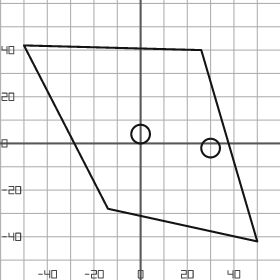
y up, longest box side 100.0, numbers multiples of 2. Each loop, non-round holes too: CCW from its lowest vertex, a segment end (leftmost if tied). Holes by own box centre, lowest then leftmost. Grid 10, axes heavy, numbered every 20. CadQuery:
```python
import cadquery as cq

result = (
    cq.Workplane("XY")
    .moveTo(50.0, -42.0)
    .lineTo(26.0, 40.0)
    .lineTo(-50.0, 42.0)
    .lineTo(-14.0, -28.0)
    .close()
    .moveTo(30.0, -2.0)
    .circle(4.0)
    .moveTo(0.0, 4.0)
    .circle(4.0)
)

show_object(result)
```